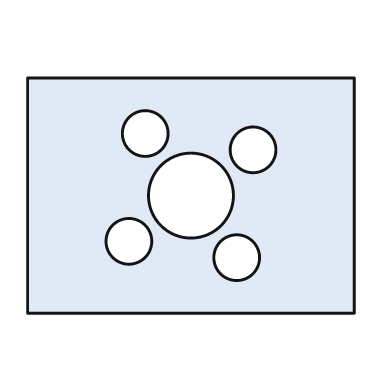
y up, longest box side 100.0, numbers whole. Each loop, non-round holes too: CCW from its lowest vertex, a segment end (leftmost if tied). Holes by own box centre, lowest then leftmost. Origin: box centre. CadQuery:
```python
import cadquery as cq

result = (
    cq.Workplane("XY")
    .moveTo(-50.0, -36.0)
    .lineTo(50.0, -36.0)
    .lineTo(50.0, 36.0)
    .lineTo(-50.0, 36.0)
    .close()
    .moveTo(14.0, -19.0)
    .circle(7.0)
    .moveTo(-19.0, -14.0)
    .circle(7.0)
    .moveTo(0.0, 0.0)
    .circle(13.0)
    .moveTo(19.0, 14.0)
    .circle(7.0)
    .moveTo(-14.0, 19.0)
    .circle(7.0)
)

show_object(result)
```